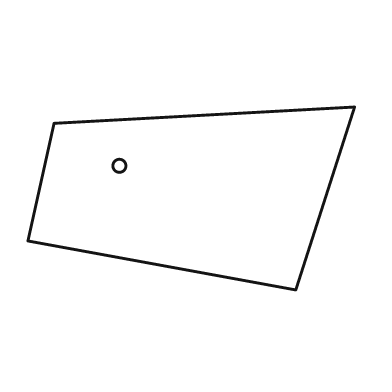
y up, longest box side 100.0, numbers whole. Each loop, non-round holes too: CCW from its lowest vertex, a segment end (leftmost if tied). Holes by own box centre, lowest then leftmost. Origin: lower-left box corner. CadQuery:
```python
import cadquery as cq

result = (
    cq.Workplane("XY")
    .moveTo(82.0, 0.0)
    .lineTo(100.0, 56.0)
    .lineTo(8.0, 51.0)
    .lineTo(0.0, 15.0)
    .close()
    .moveTo(28.0, 38.0)
    .circle(2.0)
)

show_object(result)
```